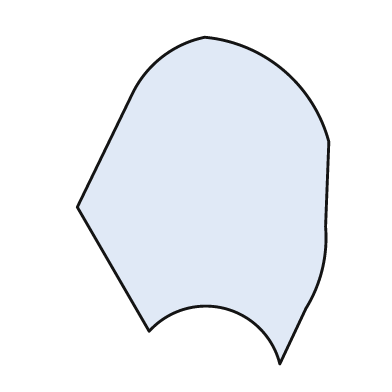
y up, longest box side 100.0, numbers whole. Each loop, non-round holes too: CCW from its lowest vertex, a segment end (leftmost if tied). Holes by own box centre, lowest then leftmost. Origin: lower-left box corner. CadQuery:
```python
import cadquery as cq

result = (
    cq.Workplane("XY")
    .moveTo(62.0, 0.0)
    .lineTo(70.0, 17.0)
    .threePointArc((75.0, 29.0), (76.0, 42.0))
    .lineTo(77.0, 68.0)
    .threePointArc((63.0, 90.0), (39.0, 100.0))
    .threePointArc((26.0, 94.0), (17.0, 83.0))
    .lineTo(0.0, 48.0)
    .lineTo(22.0, 10.0)
    .threePointArc((45.0, 17.0), (62.0, 0.0))
    .close()
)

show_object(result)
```